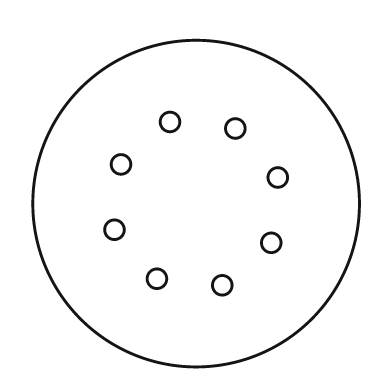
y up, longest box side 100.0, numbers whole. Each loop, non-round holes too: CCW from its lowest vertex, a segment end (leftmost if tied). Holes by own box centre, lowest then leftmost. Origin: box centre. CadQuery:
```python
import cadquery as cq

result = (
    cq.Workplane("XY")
    .moveTo(0.0, 0.0)
    .circle(50.0)
    .moveTo(8.0, -25.0)
    .circle(3.0)
    .moveTo(-12.0, -23.0)
    .circle(3.0)
    .moveTo(23.0, -12.0)
    .circle(3.0)
    .moveTo(-25.0, -8.0)
    .circle(3.0)
    .moveTo(25.0, 8.0)
    .circle(3.0)
    .moveTo(-23.0, 12.0)
    .circle(3.0)
    .moveTo(12.0, 23.0)
    .circle(3.0)
    .moveTo(-8.0, 25.0)
    .circle(3.0)
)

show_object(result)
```